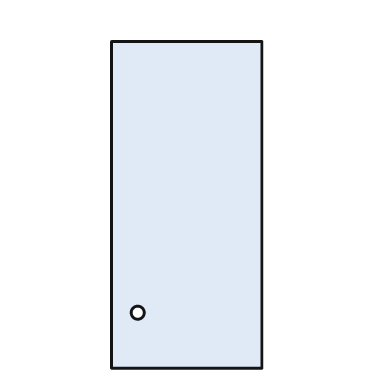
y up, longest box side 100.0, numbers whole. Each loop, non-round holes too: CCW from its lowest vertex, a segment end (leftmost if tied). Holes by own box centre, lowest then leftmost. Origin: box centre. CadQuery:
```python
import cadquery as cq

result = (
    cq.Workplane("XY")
    .moveTo(-23.0, -50.0)
    .lineTo(23.0, -50.0)
    .lineTo(23.0, 50.0)
    .lineTo(-23.0, 50.0)
    .close()
    .moveTo(-15.0, -33.0)
    .circle(2.0)
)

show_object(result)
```